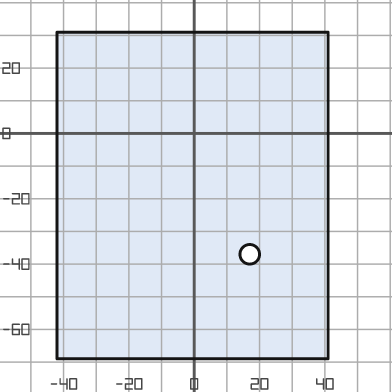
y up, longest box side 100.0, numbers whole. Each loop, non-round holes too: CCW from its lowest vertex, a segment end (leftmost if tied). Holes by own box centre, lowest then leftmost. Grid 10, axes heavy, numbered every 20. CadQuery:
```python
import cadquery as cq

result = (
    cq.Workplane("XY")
    .moveTo(-42.0, -69.0)
    .lineTo(41.0, -69.0)
    .lineTo(41.0, 31.0)
    .lineTo(-42.0, 31.0)
    .close()
    .moveTo(17.0, -37.0)
    .circle(3.0)
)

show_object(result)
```